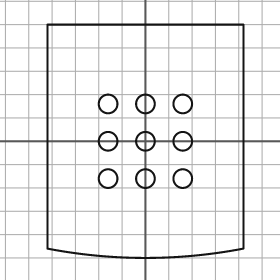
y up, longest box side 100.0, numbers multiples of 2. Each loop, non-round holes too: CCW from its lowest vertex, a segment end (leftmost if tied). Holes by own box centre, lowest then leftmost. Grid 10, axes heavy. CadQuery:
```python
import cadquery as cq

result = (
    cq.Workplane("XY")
    .moveTo(-42.0, -46.0)
    .threePointArc((0.0, -50.0), (42.0, -46.0))
    .lineTo(42.0, 50.0)
    .lineTo(-42.0, 50.0)
    .close()
    .moveTo(-16.0, -16.0)
    .circle(4.0)
    .moveTo(0.0, -16.0)
    .circle(4.0)
    .moveTo(16.0, -16.0)
    .circle(4.0)
    .moveTo(-16.0, 0.0)
    .circle(4.0)
    .moveTo(0.0, 0.0)
    .circle(4.0)
    .moveTo(16.0, 0.0)
    .circle(4.0)
    .moveTo(-16.0, 16.0)
    .circle(4.0)
    .moveTo(0.0, 16.0)
    .circle(4.0)
    .moveTo(16.0, 16.0)
    .circle(4.0)
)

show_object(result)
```